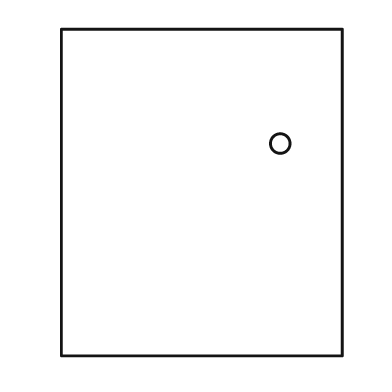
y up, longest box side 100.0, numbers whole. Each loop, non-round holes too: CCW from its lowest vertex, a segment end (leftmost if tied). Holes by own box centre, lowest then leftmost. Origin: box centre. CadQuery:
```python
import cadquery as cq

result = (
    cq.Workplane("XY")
    .moveTo(-43.0, -50.0)
    .lineTo(43.0, -50.0)
    .lineTo(43.0, 50.0)
    .lineTo(-43.0, 50.0)
    .close()
    .moveTo(24.0, 15.0)
    .circle(3.0)
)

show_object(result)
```